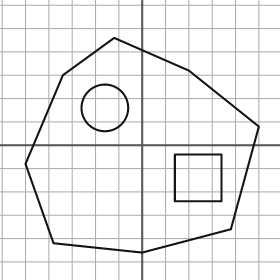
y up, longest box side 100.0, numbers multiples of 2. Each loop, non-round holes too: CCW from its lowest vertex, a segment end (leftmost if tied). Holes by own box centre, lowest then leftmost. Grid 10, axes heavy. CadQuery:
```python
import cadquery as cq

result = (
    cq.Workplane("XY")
    .moveTo(0.0, -46.0)
    .lineTo(38.0, -36.0)
    .lineTo(50.0, 8.0)
    .lineTo(20.0, 32.0)
    .lineTo(-12.0, 46.0)
    .lineTo(-34.0, 30.0)
    .lineTo(-50.0, -8.0)
    .lineTo(-38.0, -42.0)
    .close()
    .moveTo(14.0, -24.0)
    .lineTo(34.0, -24.0)
    .lineTo(34.0, -4.0)
    .lineTo(14.0, -4.0)
    .close()
    .moveTo(-16.0, 16.0)
    .circle(10.0)
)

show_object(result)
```